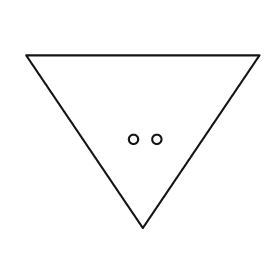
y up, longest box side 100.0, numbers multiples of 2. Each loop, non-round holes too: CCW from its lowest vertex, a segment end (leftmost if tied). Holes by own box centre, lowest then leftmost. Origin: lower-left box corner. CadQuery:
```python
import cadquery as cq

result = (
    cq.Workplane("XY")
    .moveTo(50.0, 0.0)
    .lineTo(100.0, 74.0)
    .lineTo(0.0, 74.0)
    .close()
    .moveTo(46.0, 38.0)
    .circle(2.0)
    .moveTo(56.0, 38.0)
    .circle(2.0)
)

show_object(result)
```